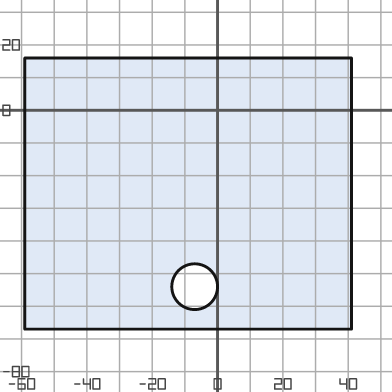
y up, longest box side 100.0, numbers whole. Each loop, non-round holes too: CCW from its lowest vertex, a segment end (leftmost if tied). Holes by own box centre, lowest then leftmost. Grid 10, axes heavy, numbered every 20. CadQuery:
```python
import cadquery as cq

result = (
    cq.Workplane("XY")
    .moveTo(-59.0, -67.0)
    .lineTo(41.0, -67.0)
    .lineTo(41.0, 16.0)
    .lineTo(-59.0, 16.0)
    .close()
    .moveTo(-7.0, -54.0)
    .circle(7.0)
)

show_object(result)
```